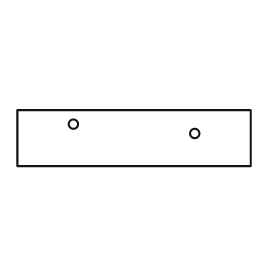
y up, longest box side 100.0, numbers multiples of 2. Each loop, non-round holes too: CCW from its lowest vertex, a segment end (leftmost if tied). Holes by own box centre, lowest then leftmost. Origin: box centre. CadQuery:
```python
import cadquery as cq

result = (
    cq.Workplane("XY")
    .moveTo(-50.0, -12.0)
    .lineTo(50.0, -12.0)
    .lineTo(50.0, 12.0)
    .lineTo(-50.0, 12.0)
    .close()
    .moveTo(26.0, 2.0)
    .circle(2.0)
    .moveTo(-26.0, 6.0)
    .circle(2.0)
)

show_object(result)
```